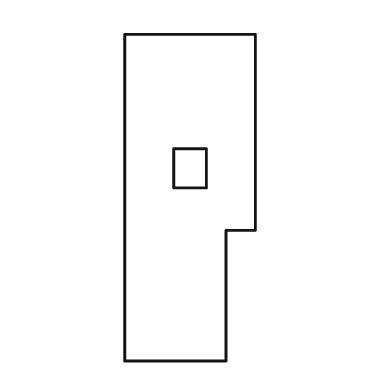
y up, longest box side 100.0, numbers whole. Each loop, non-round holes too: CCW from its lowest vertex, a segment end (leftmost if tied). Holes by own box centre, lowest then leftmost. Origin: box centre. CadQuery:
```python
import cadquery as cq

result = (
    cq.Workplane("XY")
    .moveTo(-20.0, -50.0)
    .lineTo(11.0, -50.0)
    .lineTo(11.0, -10.0)
    .lineTo(20.0, -10.0)
    .lineTo(20.0, 50.0)
    .lineTo(-20.0, 50.0)
    .close()
    .moveTo(-5.0, 3.0)
    .lineTo(5.0, 3.0)
    .lineTo(5.0, 15.0)
    .lineTo(-5.0, 15.0)
    .close()
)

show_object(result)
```